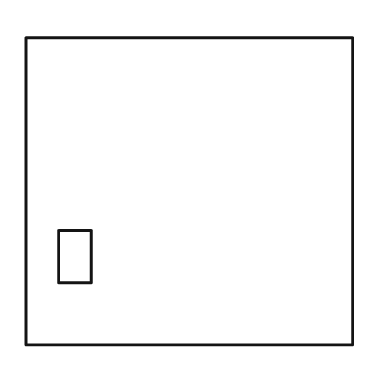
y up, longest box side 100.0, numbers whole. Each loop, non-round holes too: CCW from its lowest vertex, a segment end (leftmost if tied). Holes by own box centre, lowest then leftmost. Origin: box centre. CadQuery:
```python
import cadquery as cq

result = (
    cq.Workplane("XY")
    .moveTo(-50.0, -47.0)
    .lineTo(50.0, -47.0)
    .lineTo(50.0, 47.0)
    .lineTo(-50.0, 47.0)
    .close()
    .moveTo(-40.0, -28.0)
    .lineTo(-30.0, -28.0)
    .lineTo(-30.0, -12.0)
    .lineTo(-40.0, -12.0)
    .close()
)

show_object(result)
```